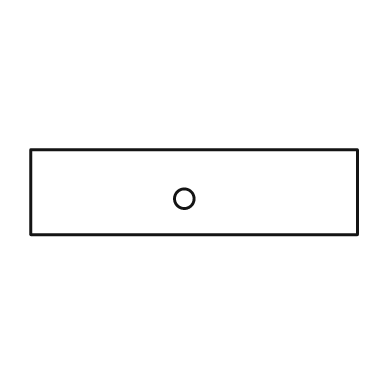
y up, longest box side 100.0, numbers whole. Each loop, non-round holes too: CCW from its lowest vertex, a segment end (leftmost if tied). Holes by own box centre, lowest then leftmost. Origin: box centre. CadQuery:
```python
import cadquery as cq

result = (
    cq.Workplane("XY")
    .moveTo(-50.0, -13.0)
    .lineTo(50.0, -13.0)
    .lineTo(50.0, 13.0)
    .lineTo(-50.0, 13.0)
    .close()
    .moveTo(-3.0, -2.0)
    .circle(3.0)
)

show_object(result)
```